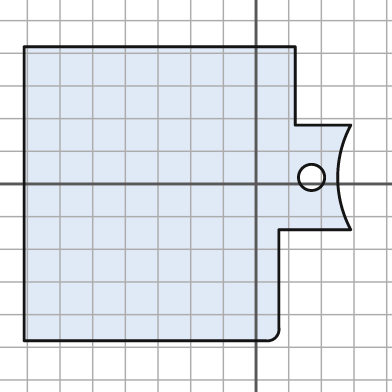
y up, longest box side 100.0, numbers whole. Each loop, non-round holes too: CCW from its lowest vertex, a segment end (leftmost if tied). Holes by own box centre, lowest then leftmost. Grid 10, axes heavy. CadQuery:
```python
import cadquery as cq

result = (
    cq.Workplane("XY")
    .moveTo(-71.0, -48.0)
    .lineTo(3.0, -48.0)
    .threePointArc((6.0, -47.0), (7.0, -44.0))
    .lineTo(7.0, -14.0)
    .lineTo(29.0, -14.0)
    .threePointArc((25.0, 2.0), (29.0, 18.0))
    .lineTo(12.0, 18.0)
    .lineTo(12.0, 42.0)
    .lineTo(-71.0, 42.0)
    .close()
    .moveTo(17.0, 2.0)
    .circle(4.0)
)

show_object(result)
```